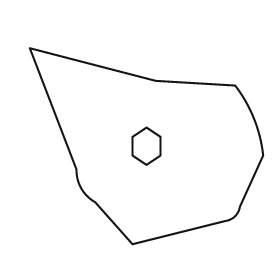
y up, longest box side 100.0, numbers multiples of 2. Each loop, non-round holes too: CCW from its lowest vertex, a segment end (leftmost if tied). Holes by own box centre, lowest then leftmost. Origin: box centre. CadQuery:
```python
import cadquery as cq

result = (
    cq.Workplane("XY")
    .moveTo(-6.0, -42.0)
    .lineTo(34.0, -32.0)
    .threePointArc((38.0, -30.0), (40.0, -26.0))
    .lineTo(50.0, -4.0)
    .threePointArc((46.0, 12.0), (38.0, 26.0))
    .lineTo(4.0, 28.0)
    .lineTo(-50.0, 42.0)
    .lineTo(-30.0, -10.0)
    .threePointArc((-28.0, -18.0), (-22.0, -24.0))
    .close()
    .moveTo(0.0, -8.0)
    .lineTo(6.0, -4.0)
    .lineTo(6.0, 4.0)
    .lineTo(0.0, 8.0)
    .lineTo(-6.0, 4.0)
    .lineTo(-6.0, -4.0)
    .close()
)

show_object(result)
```